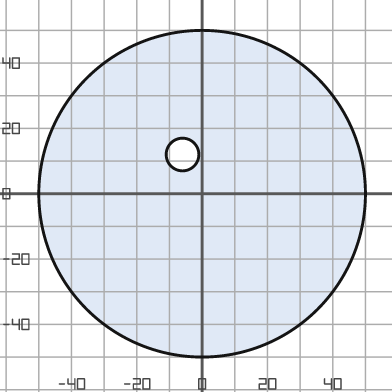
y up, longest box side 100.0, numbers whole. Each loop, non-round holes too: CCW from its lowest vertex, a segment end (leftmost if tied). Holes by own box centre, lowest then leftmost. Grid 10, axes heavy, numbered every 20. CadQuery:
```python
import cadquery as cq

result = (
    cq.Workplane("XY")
    .moveTo(0.0, 0.0)
    .circle(50.0)
    .moveTo(-6.0, 12.0)
    .circle(5.0)
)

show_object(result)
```